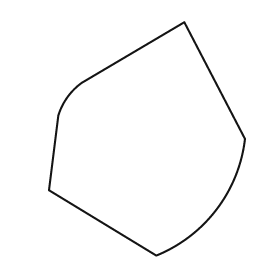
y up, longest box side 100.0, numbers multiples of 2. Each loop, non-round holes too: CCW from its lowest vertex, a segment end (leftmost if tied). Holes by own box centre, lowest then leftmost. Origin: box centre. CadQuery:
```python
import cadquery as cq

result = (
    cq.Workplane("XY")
    .moveTo(4.0, -50.0)
    .threePointArc((30.0, -30.0), (42.0, 0.0))
    .lineTo(16.0, 50.0)
    .lineTo(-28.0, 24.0)
    .threePointArc((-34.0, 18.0), (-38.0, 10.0))
    .lineTo(-42.0, -22.0)
    .close()
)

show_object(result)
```